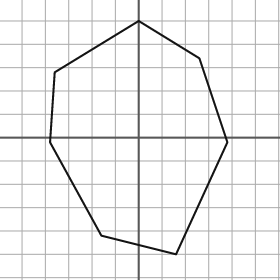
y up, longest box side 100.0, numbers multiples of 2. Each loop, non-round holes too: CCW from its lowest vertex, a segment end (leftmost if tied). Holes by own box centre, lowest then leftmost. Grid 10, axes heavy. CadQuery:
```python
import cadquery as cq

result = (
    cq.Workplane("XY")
    .moveTo(16.0, -50.0)
    .lineTo(38.0, -2.0)
    .lineTo(26.0, 34.0)
    .lineTo(0.0, 50.0)
    .lineTo(-36.0, 28.0)
    .lineTo(-38.0, -2.0)
    .lineTo(-16.0, -42.0)
    .close()
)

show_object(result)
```